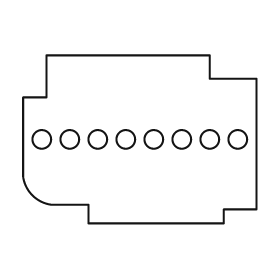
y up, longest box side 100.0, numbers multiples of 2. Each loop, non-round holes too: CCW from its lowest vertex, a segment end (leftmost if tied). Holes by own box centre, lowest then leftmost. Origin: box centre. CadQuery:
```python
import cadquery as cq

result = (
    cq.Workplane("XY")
    .moveTo(-22.0, -36.0)
    .lineTo(36.0, -36.0)
    .lineTo(36.0, -30.0)
    .lineTo(50.0, -30.0)
    .lineTo(50.0, 26.0)
    .lineTo(30.0, 26.0)
    .lineTo(30.0, 36.0)
    .lineTo(-40.0, 36.0)
    .lineTo(-40.0, 18.0)
    .lineTo(-50.0, 18.0)
    .lineTo(-50.0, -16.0)
    .threePointArc((-46.0, -24.0), (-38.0, -28.0))
    .lineTo(-22.0, -28.0)
    .close()
    .moveTo(-42.0, 0.0)
    .circle(4.0)
    .moveTo(-30.0, 0.0)
    .circle(4.0)
    .moveTo(-18.0, 0.0)
    .circle(4.0)
    .moveTo(-6.0, 0.0)
    .circle(4.0)
    .moveTo(6.0, 0.0)
    .circle(4.0)
    .moveTo(18.0, 0.0)
    .circle(4.0)
    .moveTo(30.0, 0.0)
    .circle(4.0)
    .moveTo(42.0, 0.0)
    .circle(4.0)
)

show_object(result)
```